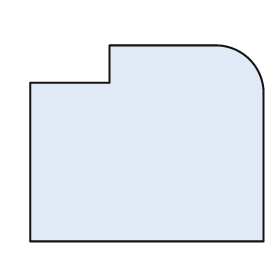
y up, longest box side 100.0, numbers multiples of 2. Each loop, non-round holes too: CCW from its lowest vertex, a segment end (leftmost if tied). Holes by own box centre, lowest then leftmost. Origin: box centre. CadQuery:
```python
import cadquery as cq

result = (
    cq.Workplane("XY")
    .moveTo(-50.0, -42.0)
    .lineTo(50.0, -42.0)
    .lineTo(50.0, 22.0)
    .threePointArc((44.0, 36.0), (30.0, 42.0))
    .lineTo(-16.0, 42.0)
    .lineTo(-16.0, 26.0)
    .lineTo(-50.0, 26.0)
    .close()
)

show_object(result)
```